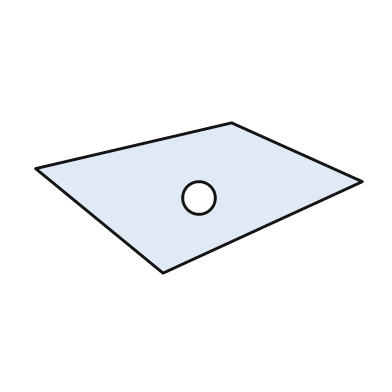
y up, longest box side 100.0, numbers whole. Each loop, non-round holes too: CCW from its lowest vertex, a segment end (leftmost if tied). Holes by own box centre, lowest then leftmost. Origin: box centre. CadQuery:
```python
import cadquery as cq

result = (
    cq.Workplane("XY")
    .moveTo(-11.0, -23.0)
    .lineTo(50.0, 5.0)
    .lineTo(10.0, 23.0)
    .lineTo(-50.0, 9.0)
    .close()
    .moveTo(0.0, 0.0)
    .circle(5.0)
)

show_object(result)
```